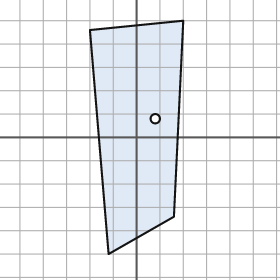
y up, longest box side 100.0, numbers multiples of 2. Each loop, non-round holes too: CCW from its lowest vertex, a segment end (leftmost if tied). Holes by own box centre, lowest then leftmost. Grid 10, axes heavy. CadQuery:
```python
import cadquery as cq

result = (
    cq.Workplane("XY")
    .moveTo(-12.0, -50.0)
    .lineTo(16.0, -34.0)
    .lineTo(20.0, 50.0)
    .lineTo(-20.0, 46.0)
    .close()
    .moveTo(8.0, 8.0)
    .circle(2.0)
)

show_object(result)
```